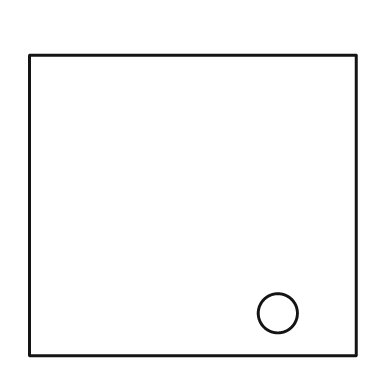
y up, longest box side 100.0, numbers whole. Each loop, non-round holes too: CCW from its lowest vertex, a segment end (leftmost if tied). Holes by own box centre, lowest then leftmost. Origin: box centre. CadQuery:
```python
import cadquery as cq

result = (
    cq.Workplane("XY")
    .moveTo(-50.0, -46.0)
    .lineTo(50.0, -46.0)
    .lineTo(50.0, 46.0)
    .lineTo(-50.0, 46.0)
    .close()
    .moveTo(26.0, -33.0)
    .circle(6.0)
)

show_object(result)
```